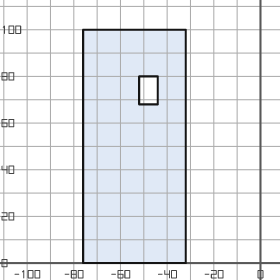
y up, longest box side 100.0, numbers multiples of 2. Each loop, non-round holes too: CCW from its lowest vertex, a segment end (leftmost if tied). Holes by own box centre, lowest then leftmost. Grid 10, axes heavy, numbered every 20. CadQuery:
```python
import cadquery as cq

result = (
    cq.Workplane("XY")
    .moveTo(-76.0, 0.0)
    .lineTo(-32.0, 0.0)
    .lineTo(-32.0, 100.0)
    .lineTo(-76.0, 100.0)
    .close()
    .moveTo(-52.0, 68.0)
    .lineTo(-44.0, 68.0)
    .lineTo(-44.0, 80.0)
    .lineTo(-52.0, 80.0)
    .close()
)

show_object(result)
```